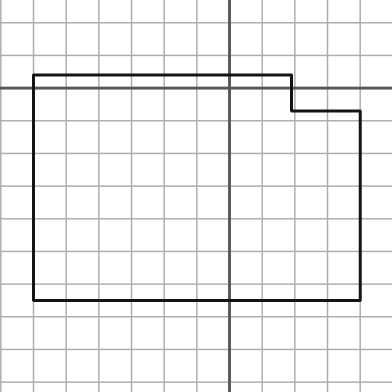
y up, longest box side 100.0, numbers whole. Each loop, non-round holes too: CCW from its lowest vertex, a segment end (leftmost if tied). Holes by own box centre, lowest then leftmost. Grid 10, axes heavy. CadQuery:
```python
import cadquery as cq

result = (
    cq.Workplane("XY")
    .moveTo(-60.0, -65.0)
    .lineTo(40.0, -65.0)
    .lineTo(40.0, -7.0)
    .lineTo(19.0, -7.0)
    .lineTo(19.0, 4.0)
    .lineTo(-60.0, 4.0)
    .close()
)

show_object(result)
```